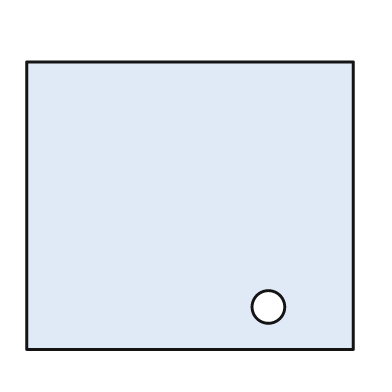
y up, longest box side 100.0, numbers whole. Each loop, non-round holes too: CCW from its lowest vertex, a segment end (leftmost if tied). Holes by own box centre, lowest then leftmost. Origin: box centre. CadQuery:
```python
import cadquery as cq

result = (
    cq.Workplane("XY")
    .moveTo(-50.0, -44.0)
    .lineTo(50.0, -44.0)
    .lineTo(50.0, 44.0)
    .lineTo(-50.0, 44.0)
    .close()
    .moveTo(24.0, -31.0)
    .circle(5.0)
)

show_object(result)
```